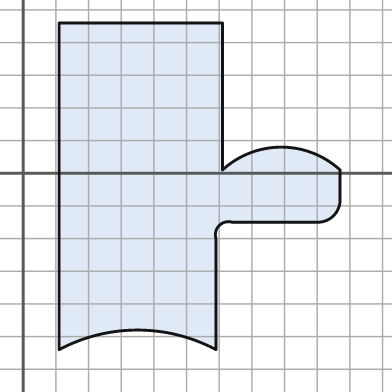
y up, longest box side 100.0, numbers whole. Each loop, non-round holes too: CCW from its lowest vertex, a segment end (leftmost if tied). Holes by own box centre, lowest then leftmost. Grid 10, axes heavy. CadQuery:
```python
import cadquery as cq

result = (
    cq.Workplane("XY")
    .moveTo(11.0, -54.0)
    .threePointArc((35.0, -48.0), (59.0, -54.0))
    .lineTo(59.0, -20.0)
    .threePointArc((60.0, -16.0), (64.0, -15.0))
    .lineTo(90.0, -15.0)
    .threePointArc((95.0, -13.0), (97.0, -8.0))
    .lineTo(97.0, 1.0)
    .threePointArc((79.0, 8.0), (61.0, 1.0))
    .lineTo(61.0, 46.0)
    .lineTo(11.0, 46.0)
    .close()
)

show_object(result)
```